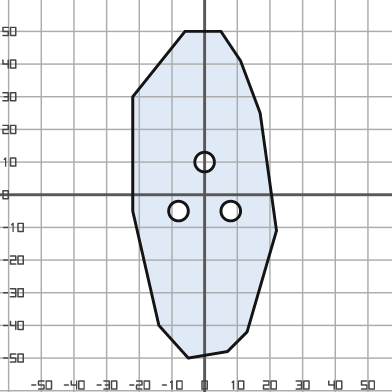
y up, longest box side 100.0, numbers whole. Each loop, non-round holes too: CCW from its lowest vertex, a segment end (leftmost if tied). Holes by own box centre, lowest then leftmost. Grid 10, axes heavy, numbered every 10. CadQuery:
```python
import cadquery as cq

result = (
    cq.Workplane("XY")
    .moveTo(-5.0, -50.0)
    .lineTo(7.0, -48.0)
    .lineTo(13.0, -42.0)
    .lineTo(22.0, -11.0)
    .lineTo(17.0, 25.0)
    .lineTo(11.0, 41.0)
    .lineTo(5.0, 50.0)
    .lineTo(-6.0, 50.0)
    .lineTo(-22.0, 30.0)
    .lineTo(-22.0, -5.0)
    .lineTo(-14.0, -40.0)
    .close()
    .moveTo(-8.0, -5.0)
    .circle(3.0)
    .moveTo(8.0, -5.0)
    .circle(3.0)
    .moveTo(0.0, 10.0)
    .circle(3.0)
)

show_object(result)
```